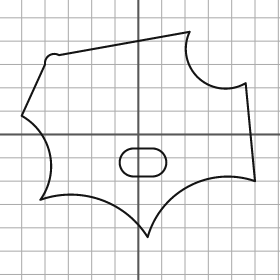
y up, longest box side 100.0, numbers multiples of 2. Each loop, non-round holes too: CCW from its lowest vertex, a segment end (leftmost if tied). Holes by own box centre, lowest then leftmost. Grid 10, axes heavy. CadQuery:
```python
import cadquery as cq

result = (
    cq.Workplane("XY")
    .moveTo(4.0, -44.0)
    .threePointArc((22.0, -22.0), (50.0, -20.0))
    .lineTo(46.0, 22.0)
    .threePointArc((26.0, 24.0), (22.0, 44.0))
    .lineTo(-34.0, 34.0)
    .threePointArc((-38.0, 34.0), (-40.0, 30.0))
    .lineTo(-50.0, 8.0)
    .threePointArc((-38.0, -8.0), (-42.0, -28.0))
    .threePointArc((-16.0, -28.0), (4.0, -44.0))
    .close()
    .moveTo(-2.0, -18.0)
    .lineTo(6.0, -18.0)
    .threePointArc((12.0, -12.0), (6.0, -6.0))
    .lineTo(-2.0, -6.0)
    .threePointArc((-8.0, -12.0), (-2.0, -18.0))
    .close()
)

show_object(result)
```